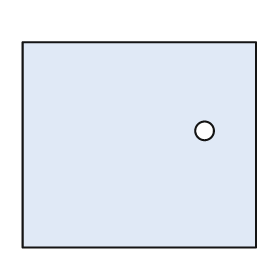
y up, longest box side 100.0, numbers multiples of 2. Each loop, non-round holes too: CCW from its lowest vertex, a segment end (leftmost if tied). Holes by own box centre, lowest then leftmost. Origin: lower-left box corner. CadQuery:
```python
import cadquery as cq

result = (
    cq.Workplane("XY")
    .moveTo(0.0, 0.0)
    .lineTo(100.0, 0.0)
    .lineTo(100.0, 88.0)
    .lineTo(0.0, 88.0)
    .close()
    .moveTo(78.0, 50.0)
    .circle(4.0)
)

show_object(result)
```